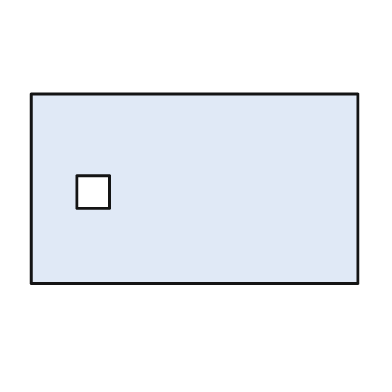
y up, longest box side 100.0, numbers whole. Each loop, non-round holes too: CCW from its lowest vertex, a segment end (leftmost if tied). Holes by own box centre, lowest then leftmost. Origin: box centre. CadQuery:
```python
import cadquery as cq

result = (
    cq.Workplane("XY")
    .moveTo(-50.0, -29.0)
    .lineTo(50.0, -29.0)
    .lineTo(50.0, 29.0)
    .lineTo(-50.0, 29.0)
    .close()
    .moveTo(-36.0, -6.0)
    .lineTo(-26.0, -6.0)
    .lineTo(-26.0, 4.0)
    .lineTo(-36.0, 4.0)
    .close()
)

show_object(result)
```